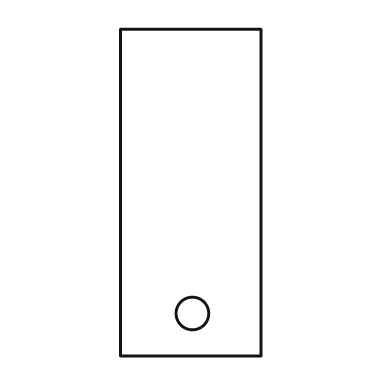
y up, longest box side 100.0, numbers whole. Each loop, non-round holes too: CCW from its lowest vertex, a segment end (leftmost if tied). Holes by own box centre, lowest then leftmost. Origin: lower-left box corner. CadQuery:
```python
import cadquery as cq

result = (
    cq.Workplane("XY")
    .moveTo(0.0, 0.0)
    .lineTo(43.0, 0.0)
    .lineTo(43.0, 100.0)
    .lineTo(0.0, 100.0)
    .close()
    .moveTo(22.0, 13.0)
    .circle(5.0)
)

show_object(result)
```